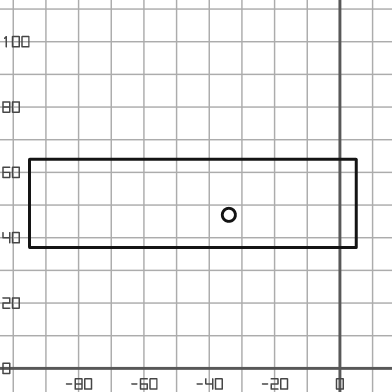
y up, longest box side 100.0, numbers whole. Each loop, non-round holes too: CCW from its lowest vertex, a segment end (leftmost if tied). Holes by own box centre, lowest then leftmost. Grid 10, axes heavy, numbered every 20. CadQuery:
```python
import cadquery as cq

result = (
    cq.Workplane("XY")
    .moveTo(-95.0, 37.0)
    .lineTo(5.0, 37.0)
    .lineTo(5.0, 64.0)
    .lineTo(-95.0, 64.0)
    .close()
    .moveTo(-34.0, 47.0)
    .circle(2.0)
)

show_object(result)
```